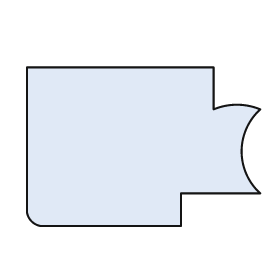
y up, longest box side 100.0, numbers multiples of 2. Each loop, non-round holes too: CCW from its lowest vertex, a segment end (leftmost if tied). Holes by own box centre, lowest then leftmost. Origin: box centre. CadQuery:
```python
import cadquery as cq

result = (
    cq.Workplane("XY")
    .moveTo(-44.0, -34.0)
    .lineTo(16.0, -34.0)
    .lineTo(16.0, -20.0)
    .lineTo(50.0, -20.0)
    .threePointArc((42.0, -2.0), (50.0, 16.0))
    .threePointArc((40.0, 18.0), (30.0, 16.0))
    .lineTo(30.0, 34.0)
    .lineTo(-50.0, 34.0)
    .lineTo(-50.0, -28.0)
    .threePointArc((-48.0, -32.0), (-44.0, -34.0))
    .close()
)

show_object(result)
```